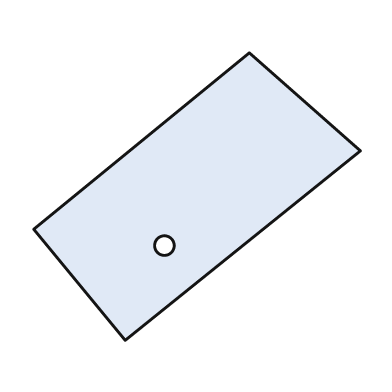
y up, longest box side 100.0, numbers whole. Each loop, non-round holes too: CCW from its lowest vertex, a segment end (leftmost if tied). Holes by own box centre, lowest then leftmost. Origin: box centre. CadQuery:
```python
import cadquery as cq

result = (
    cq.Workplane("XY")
    .moveTo(-22.0, -44.0)
    .lineTo(50.0, 14.0)
    .lineTo(16.0, 44.0)
    .lineTo(-50.0, -10.0)
    .close()
    .moveTo(-10.0, -15.0)
    .circle(3.0)
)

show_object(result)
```